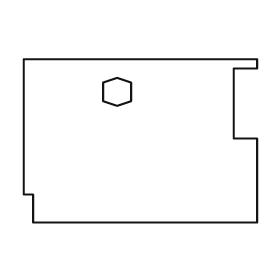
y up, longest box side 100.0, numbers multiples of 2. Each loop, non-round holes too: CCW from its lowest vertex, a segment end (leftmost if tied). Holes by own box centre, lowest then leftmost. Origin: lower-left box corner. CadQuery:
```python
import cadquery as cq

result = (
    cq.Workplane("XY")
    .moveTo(4.0, 0.0)
    .lineTo(100.0, 0.0)
    .lineTo(100.0, 36.0)
    .lineTo(90.0, 36.0)
    .lineTo(90.0, 66.0)
    .lineTo(100.0, 66.0)
    .lineTo(100.0, 70.0)
    .lineTo(0.0, 70.0)
    .lineTo(0.0, 12.0)
    .lineTo(4.0, 12.0)
    .close()
    .moveTo(40.0, 50.0)
    .lineTo(46.0, 52.0)
    .lineTo(46.0, 60.0)
    .lineTo(40.0, 62.0)
    .lineTo(34.0, 60.0)
    .lineTo(34.0, 52.0)
    .close()
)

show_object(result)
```